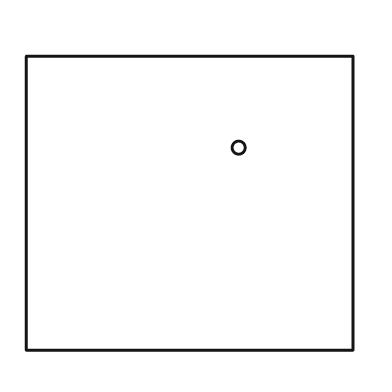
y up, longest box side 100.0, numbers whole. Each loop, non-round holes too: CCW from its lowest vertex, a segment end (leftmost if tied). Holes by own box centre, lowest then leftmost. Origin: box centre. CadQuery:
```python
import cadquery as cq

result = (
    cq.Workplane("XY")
    .moveTo(-50.0, -45.0)
    .lineTo(50.0, -45.0)
    .lineTo(50.0, 45.0)
    .lineTo(-50.0, 45.0)
    .close()
    .moveTo(15.0, 17.0)
    .circle(2.0)
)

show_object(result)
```